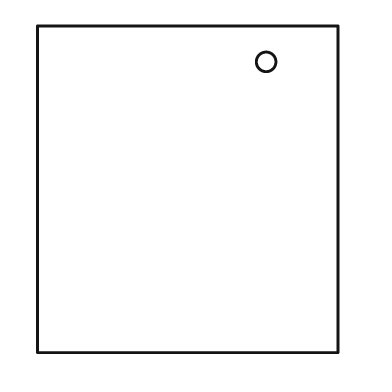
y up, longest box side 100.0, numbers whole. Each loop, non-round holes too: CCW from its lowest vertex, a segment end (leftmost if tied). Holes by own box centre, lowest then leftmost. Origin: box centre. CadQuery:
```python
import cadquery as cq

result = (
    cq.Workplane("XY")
    .moveTo(-46.0, -50.0)
    .lineTo(46.0, -50.0)
    .lineTo(46.0, 50.0)
    .lineTo(-46.0, 50.0)
    .close()
    .moveTo(24.0, 39.0)
    .circle(3.0)
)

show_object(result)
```